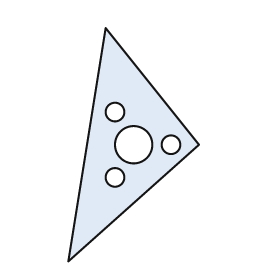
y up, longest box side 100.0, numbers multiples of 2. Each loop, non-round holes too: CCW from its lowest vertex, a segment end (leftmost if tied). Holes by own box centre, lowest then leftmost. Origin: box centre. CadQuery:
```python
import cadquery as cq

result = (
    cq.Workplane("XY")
    .moveTo(-28.0, -50.0)
    .lineTo(28.0, 0.0)
    .lineTo(-12.0, 50.0)
    .close()
    .moveTo(-8.0, -14.0)
    .circle(4.0)
    .moveTo(0.0, 0.0)
    .circle(8.0)
    .moveTo(16.0, 0.0)
    .circle(4.0)
    .moveTo(-8.0, 14.0)
    .circle(4.0)
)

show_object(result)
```